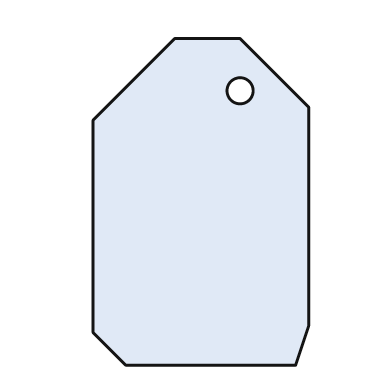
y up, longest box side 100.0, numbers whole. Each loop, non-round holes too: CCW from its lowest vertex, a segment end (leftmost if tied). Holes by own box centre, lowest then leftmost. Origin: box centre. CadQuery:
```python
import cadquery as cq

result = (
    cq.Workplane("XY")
    .moveTo(-23.0, -50.0)
    .lineTo(29.0, -50.0)
    .lineTo(33.0, -38.0)
    .lineTo(33.0, 29.0)
    .lineTo(12.0, 50.0)
    .lineTo(-8.0, 50.0)
    .lineTo(-33.0, 25.0)
    .lineTo(-33.0, -40.0)
    .close()
    .moveTo(12.0, 34.0)
    .circle(4.0)
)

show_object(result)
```